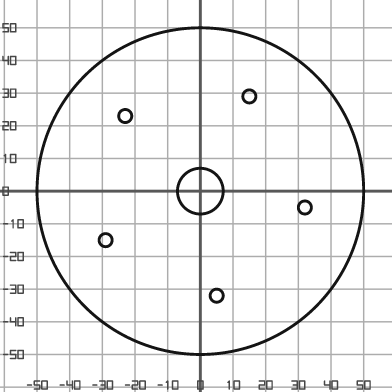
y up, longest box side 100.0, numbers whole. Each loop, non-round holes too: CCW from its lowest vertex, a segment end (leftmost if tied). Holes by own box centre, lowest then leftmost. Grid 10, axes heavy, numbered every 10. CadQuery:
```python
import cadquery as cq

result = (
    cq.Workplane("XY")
    .moveTo(0.0, 0.0)
    .circle(50.0)
    .moveTo(5.0, -32.0)
    .circle(2.0)
    .moveTo(-29.0, -15.0)
    .circle(2.0)
    .moveTo(32.0, -5.0)
    .circle(2.0)
    .moveTo(0.0, 0.0)
    .circle(7.0)
    .moveTo(-23.0, 23.0)
    .circle(2.0)
    .moveTo(15.0, 29.0)
    .circle(2.0)
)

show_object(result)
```